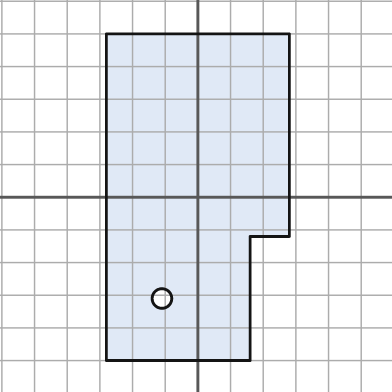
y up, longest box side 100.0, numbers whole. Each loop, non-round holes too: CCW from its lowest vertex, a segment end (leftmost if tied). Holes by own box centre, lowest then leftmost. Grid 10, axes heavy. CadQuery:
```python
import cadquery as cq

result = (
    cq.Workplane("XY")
    .moveTo(-28.0, -50.0)
    .lineTo(16.0, -50.0)
    .lineTo(16.0, -12.0)
    .lineTo(28.0, -12.0)
    .lineTo(28.0, 50.0)
    .lineTo(-28.0, 50.0)
    .close()
    .moveTo(-11.0, -31.0)
    .circle(3.0)
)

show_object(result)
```